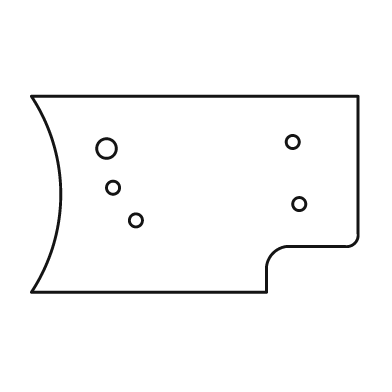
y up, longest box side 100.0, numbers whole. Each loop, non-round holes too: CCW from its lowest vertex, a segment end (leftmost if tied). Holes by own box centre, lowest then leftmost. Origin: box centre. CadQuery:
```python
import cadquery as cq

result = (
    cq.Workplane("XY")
    .moveTo(-50.0, -30.0)
    .lineTo(22.0, -30.0)
    .lineTo(22.0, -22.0)
    .threePointArc((24.0, -18.0), (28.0, -16.0))
    .lineTo(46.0, -16.0)
    .threePointArc((49.0, -15.0), (50.0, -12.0))
    .lineTo(50.0, 30.0)
    .lineTo(-50.0, 30.0)
    .threePointArc((-41.0, 0.0), (-50.0, -30.0))
    .close()
    .moveTo(-18.0, -8.0)
    .circle(2.0)
    .moveTo(32.0, -3.0)
    .circle(2.0)
    .moveTo(-25.0, 2.0)
    .circle(2.0)
    .moveTo(-27.0, 14.0)
    .circle(3.0)
    .moveTo(30.0, 16.0)
    .circle(2.0)
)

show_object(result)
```